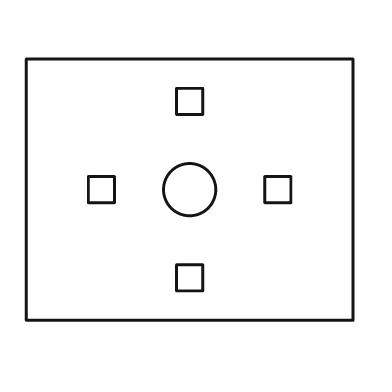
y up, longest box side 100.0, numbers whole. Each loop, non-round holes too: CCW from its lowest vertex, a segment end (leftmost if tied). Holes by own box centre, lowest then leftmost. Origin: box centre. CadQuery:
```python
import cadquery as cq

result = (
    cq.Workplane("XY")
    .moveTo(-50.0, -40.0)
    .lineTo(50.0, -40.0)
    .lineTo(50.0, 40.0)
    .lineTo(-50.0, 40.0)
    .close()
    .moveTo(-4.0, -31.0)
    .lineTo(4.0, -31.0)
    .lineTo(4.0, -23.0)
    .lineTo(-4.0, -23.0)
    .close()
    .moveTo(-31.0, -4.0)
    .lineTo(-23.0, -4.0)
    .lineTo(-23.0, 4.0)
    .lineTo(-31.0, 4.0)
    .close()
    .moveTo(0.0, 0.0)
    .circle(8.0)
    .moveTo(23.0, -4.0)
    .lineTo(31.0, -4.0)
    .lineTo(31.0, 4.0)
    .lineTo(23.0, 4.0)
    .close()
    .moveTo(-4.0, 23.0)
    .lineTo(4.0, 23.0)
    .lineTo(4.0, 31.0)
    .lineTo(-4.0, 31.0)
    .close()
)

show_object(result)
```